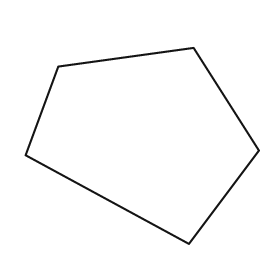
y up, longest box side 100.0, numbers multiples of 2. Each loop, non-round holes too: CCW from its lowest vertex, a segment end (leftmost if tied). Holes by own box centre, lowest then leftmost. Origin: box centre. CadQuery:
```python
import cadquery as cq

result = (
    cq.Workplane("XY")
    .moveTo(20.0, -42.0)
    .lineTo(50.0, -2.0)
    .lineTo(22.0, 42.0)
    .lineTo(-36.0, 34.0)
    .lineTo(-50.0, -4.0)
    .close()
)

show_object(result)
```